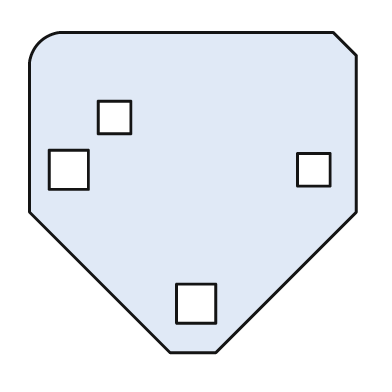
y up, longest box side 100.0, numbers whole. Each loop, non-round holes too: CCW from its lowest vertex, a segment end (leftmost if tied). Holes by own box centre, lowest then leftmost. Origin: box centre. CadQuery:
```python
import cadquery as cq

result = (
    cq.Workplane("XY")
    .moveTo(-7.0, -49.0)
    .lineTo(7.0, -49.0)
    .lineTo(50.0, -6.0)
    .lineTo(50.0, 42.0)
    .lineTo(43.0, 49.0)
    .lineTo(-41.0, 49.0)
    .threePointArc((-47.0, 46.0), (-50.0, 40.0))
    .lineTo(-50.0, -6.0)
    .close()
    .moveTo(-5.0, -40.0)
    .lineTo(7.0, -40.0)
    .lineTo(7.0, -28.0)
    .lineTo(-5.0, -28.0)
    .close()
    .moveTo(-44.0, 1.0)
    .lineTo(-32.0, 1.0)
    .lineTo(-32.0, 13.0)
    .lineTo(-44.0, 13.0)
    .close()
    .moveTo(32.0, 2.0)
    .lineTo(42.0, 2.0)
    .lineTo(42.0, 12.0)
    .lineTo(32.0, 12.0)
    .close()
    .moveTo(-29.0, 18.0)
    .lineTo(-19.0, 18.0)
    .lineTo(-19.0, 28.0)
    .lineTo(-29.0, 28.0)
    .close()
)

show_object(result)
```